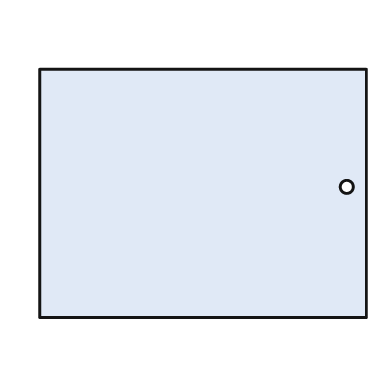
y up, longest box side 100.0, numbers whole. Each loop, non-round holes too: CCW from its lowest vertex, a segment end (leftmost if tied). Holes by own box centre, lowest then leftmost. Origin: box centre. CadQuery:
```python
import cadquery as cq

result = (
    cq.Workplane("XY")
    .moveTo(-50.0, -38.0)
    .lineTo(50.0, -38.0)
    .lineTo(50.0, 38.0)
    .lineTo(-50.0, 38.0)
    .close()
    .moveTo(44.0, 2.0)
    .circle(2.0)
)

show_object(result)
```